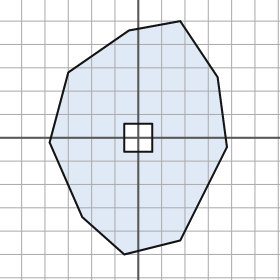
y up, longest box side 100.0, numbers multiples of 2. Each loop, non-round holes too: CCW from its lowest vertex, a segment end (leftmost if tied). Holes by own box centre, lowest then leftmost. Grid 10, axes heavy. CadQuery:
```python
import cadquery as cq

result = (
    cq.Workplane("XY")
    .moveTo(-6.0, -50.0)
    .lineTo(18.0, -44.0)
    .lineTo(38.0, -4.0)
    .lineTo(34.0, 26.0)
    .lineTo(18.0, 50.0)
    .lineTo(-4.0, 46.0)
    .lineTo(-30.0, 28.0)
    .lineTo(-38.0, -2.0)
    .lineTo(-24.0, -34.0)
    .close()
    .moveTo(-6.0, -6.0)
    .lineTo(6.0, -6.0)
    .lineTo(6.0, 6.0)
    .lineTo(-6.0, 6.0)
    .close()
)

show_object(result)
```